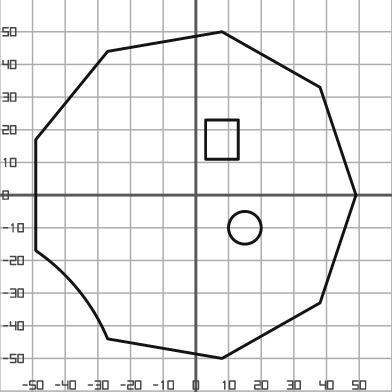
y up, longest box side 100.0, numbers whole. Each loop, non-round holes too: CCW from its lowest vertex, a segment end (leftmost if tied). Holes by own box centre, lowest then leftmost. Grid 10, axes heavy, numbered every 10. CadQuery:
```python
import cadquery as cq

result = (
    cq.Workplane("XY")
    .moveTo(8.0, -50.0)
    .lineTo(38.0, -33.0)
    .lineTo(49.0, 0.0)
    .lineTo(38.0, 33.0)
    .lineTo(8.0, 50.0)
    .lineTo(-27.0, 44.0)
    .lineTo(-49.0, 17.0)
    .lineTo(-49.0, -17.0)
    .threePointArc((-36.0, -29.0), (-27.0, -44.0))
    .close()
    .moveTo(15.0, -10.0)
    .circle(5.0)
    .moveTo(3.0, 11.0)
    .lineTo(13.0, 11.0)
    .lineTo(13.0, 23.0)
    .lineTo(3.0, 23.0)
    .close()
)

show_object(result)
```